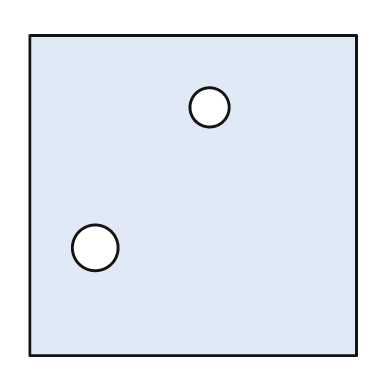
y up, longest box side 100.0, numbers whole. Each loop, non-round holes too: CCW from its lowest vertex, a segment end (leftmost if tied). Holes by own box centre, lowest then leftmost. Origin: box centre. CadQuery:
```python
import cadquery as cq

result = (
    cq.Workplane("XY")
    .moveTo(-50.0, -49.0)
    .lineTo(50.0, -49.0)
    .lineTo(50.0, 49.0)
    .lineTo(-50.0, 49.0)
    .close()
    .moveTo(-30.0, -16.0)
    .circle(7.0)
    .moveTo(5.0, 27.0)
    .circle(6.0)
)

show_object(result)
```